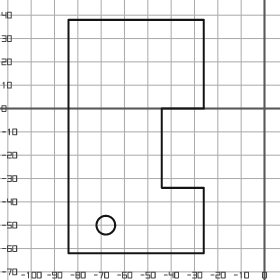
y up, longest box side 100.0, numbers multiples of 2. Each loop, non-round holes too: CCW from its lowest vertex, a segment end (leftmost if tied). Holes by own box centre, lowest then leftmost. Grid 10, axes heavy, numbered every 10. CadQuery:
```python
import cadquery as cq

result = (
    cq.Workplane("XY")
    .moveTo(-84.0, -62.0)
    .lineTo(-26.0, -62.0)
    .lineTo(-26.0, -34.0)
    .lineTo(-44.0, -34.0)
    .lineTo(-44.0, 0.0)
    .lineTo(-26.0, 0.0)
    .lineTo(-26.0, 38.0)
    .lineTo(-84.0, 38.0)
    .close()
    .moveTo(-68.0, -50.0)
    .circle(4.0)
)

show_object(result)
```